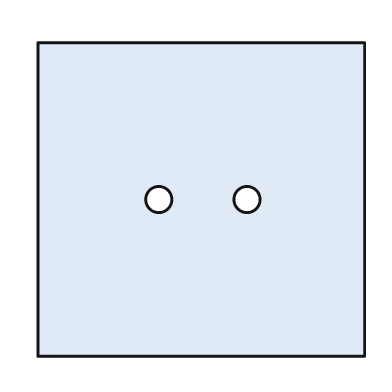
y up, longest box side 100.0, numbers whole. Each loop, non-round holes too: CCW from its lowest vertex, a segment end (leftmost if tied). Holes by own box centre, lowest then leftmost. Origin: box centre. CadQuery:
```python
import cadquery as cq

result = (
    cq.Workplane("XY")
    .moveTo(-50.0, -48.0)
    .lineTo(50.0, -48.0)
    .lineTo(50.0, 48.0)
    .lineTo(-50.0, 48.0)
    .close()
    .moveTo(-13.0, 0.0)
    .circle(4.0)
    .moveTo(14.0, 0.0)
    .circle(4.0)
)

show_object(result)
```